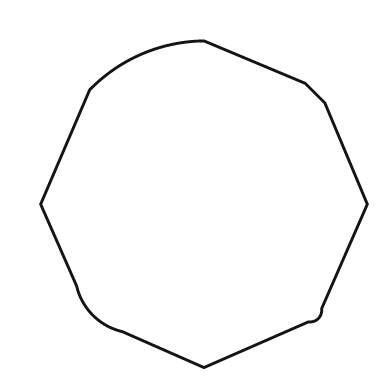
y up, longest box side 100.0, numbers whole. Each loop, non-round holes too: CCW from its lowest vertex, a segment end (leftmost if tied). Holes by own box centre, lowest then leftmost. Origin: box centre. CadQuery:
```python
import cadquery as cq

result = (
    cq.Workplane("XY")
    .moveTo(0.0, -50.0)
    .lineTo(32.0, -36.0)
    .threePointArc((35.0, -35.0), (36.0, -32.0))
    .lineTo(50.0, 0.0)
    .lineTo(37.0, 31.0)
    .lineTo(31.0, 37.0)
    .lineTo(0.0, 50.0)
    .threePointArc((-19.0, 46.0), (-35.0, 35.0))
    .lineTo(-50.0, 0.0)
    .lineTo(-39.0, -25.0)
    .threePointArc((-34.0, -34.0), (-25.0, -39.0))
    .close()
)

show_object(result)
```